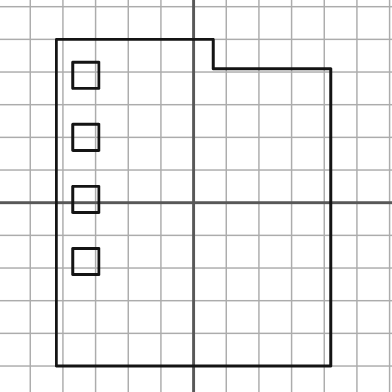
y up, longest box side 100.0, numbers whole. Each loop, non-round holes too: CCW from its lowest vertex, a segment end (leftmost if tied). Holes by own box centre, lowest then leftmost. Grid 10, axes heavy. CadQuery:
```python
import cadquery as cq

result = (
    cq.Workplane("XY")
    .moveTo(-42.0, -50.0)
    .lineTo(42.0, -50.0)
    .lineTo(42.0, 41.0)
    .lineTo(6.0, 41.0)
    .lineTo(6.0, 50.0)
    .lineTo(-42.0, 50.0)
    .close()
    .moveTo(-37.0, -22.0)
    .lineTo(-29.0, -22.0)
    .lineTo(-29.0, -14.0)
    .lineTo(-37.0, -14.0)
    .close()
    .moveTo(-37.0, -3.0)
    .lineTo(-29.0, -3.0)
    .lineTo(-29.0, 5.0)
    .lineTo(-37.0, 5.0)
    .close()
    .moveTo(-37.0, 16.0)
    .lineTo(-29.0, 16.0)
    .lineTo(-29.0, 24.0)
    .lineTo(-37.0, 24.0)
    .close()
    .moveTo(-37.0, 35.0)
    .lineTo(-29.0, 35.0)
    .lineTo(-29.0, 43.0)
    .lineTo(-37.0, 43.0)
    .close()
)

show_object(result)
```